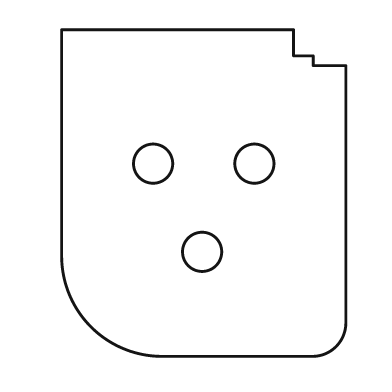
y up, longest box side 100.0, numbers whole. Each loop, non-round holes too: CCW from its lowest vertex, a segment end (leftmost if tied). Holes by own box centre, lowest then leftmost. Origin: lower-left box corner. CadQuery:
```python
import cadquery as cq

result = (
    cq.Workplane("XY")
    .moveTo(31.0, 0.0)
    .lineTo(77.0, 0.0)
    .threePointArc((84.0, 3.0), (87.0, 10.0))
    .lineTo(87.0, 89.0)
    .lineTo(77.0, 89.0)
    .lineTo(77.0, 92.0)
    .lineTo(71.0, 92.0)
    .lineTo(71.0, 100.0)
    .lineTo(0.0, 100.0)
    .lineTo(0.0, 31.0)
    .threePointArc((9.0, 9.0), (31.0, 0.0))
    .close()
    .moveTo(43.0, 32.0)
    .circle(6.0)
    .moveTo(28.0, 59.0)
    .circle(6.0)
    .moveTo(59.0, 59.0)
    .circle(6.0)
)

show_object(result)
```